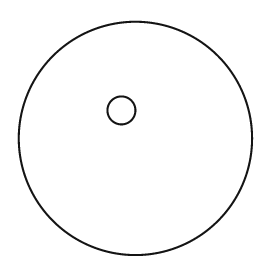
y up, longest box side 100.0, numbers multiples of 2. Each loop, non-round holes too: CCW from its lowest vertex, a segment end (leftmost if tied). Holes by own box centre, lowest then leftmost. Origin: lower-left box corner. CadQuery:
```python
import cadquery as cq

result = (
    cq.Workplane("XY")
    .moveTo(50.0, 50.0)
    .circle(50.0)
    .moveTo(44.0, 62.0)
    .circle(6.0)
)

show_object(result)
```